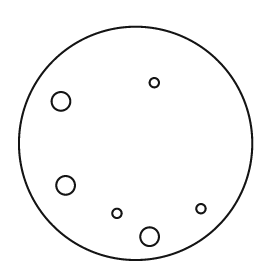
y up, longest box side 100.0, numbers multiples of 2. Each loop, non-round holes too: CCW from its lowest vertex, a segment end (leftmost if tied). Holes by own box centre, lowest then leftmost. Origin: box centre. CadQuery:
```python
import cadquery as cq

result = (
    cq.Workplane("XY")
    .moveTo(0.0, 0.0)
    .circle(50.0)
    .moveTo(6.0, -40.0)
    .circle(4.0)
    .moveTo(-8.0, -30.0)
    .circle(2.0)
    .moveTo(28.0, -28.0)
    .circle(2.0)
    .moveTo(-30.0, -18.0)
    .circle(4.0)
    .moveTo(-32.0, 18.0)
    .circle(4.0)
    .moveTo(8.0, 26.0)
    .circle(2.0)
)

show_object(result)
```